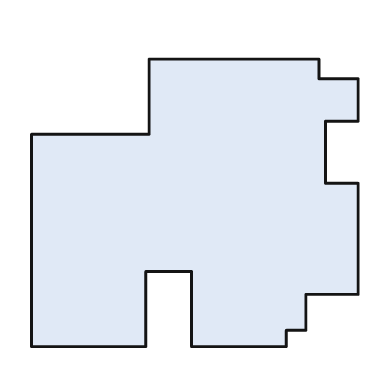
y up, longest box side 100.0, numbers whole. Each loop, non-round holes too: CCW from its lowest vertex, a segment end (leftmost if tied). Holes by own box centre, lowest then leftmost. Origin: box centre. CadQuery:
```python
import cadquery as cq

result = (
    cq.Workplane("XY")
    .moveTo(-50.0, -44.0)
    .lineTo(-15.0, -44.0)
    .lineTo(-15.0, -21.0)
    .lineTo(-1.0, -21.0)
    .lineTo(-1.0, -44.0)
    .lineTo(28.0, -44.0)
    .lineTo(28.0, -39.0)
    .lineTo(34.0, -39.0)
    .lineTo(34.0, -28.0)
    .lineTo(50.0, -28.0)
    .lineTo(50.0, 6.0)
    .lineTo(40.0, 6.0)
    .lineTo(40.0, 25.0)
    .lineTo(50.0, 25.0)
    .lineTo(50.0, 38.0)
    .lineTo(38.0, 38.0)
    .lineTo(38.0, 44.0)
    .lineTo(-14.0, 44.0)
    .lineTo(-14.0, 21.0)
    .lineTo(-50.0, 21.0)
    .close()
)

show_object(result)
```